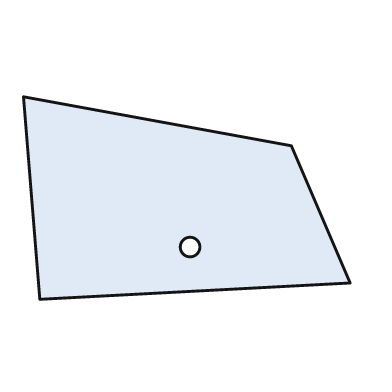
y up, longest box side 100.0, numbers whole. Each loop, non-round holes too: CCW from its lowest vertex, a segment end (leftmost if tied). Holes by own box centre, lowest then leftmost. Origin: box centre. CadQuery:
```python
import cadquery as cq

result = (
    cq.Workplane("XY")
    .moveTo(-45.0, -31.0)
    .lineTo(50.0, -26.0)
    .lineTo(32.0, 16.0)
    .lineTo(-50.0, 31.0)
    .close()
    .moveTo(1.0, -15.0)
    .circle(3.0)
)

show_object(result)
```